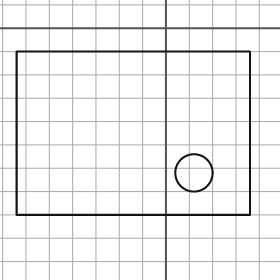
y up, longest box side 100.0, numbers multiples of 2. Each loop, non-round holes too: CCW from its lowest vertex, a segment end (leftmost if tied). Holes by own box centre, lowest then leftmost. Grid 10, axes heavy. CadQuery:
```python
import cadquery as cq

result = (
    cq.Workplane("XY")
    .moveTo(-64.0, -80.0)
    .lineTo(36.0, -80.0)
    .lineTo(36.0, -10.0)
    .lineTo(-64.0, -10.0)
    .close()
    .moveTo(12.0, -62.0)
    .circle(8.0)
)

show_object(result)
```